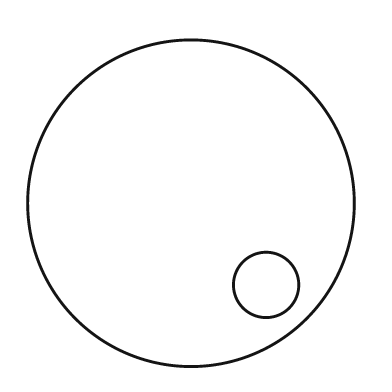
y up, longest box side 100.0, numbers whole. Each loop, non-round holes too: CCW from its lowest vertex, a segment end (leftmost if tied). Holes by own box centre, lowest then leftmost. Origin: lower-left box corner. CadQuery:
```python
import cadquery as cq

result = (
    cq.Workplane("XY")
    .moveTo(50.0, 50.0)
    .circle(50.0)
    .moveTo(73.0, 25.0)
    .circle(10.0)
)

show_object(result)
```